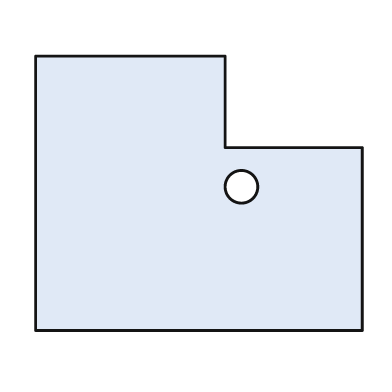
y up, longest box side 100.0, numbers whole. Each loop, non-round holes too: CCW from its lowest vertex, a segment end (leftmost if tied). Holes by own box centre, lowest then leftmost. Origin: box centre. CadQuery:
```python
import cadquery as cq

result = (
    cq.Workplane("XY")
    .moveTo(-50.0, -42.0)
    .lineTo(50.0, -42.0)
    .lineTo(50.0, 14.0)
    .lineTo(8.0, 14.0)
    .lineTo(8.0, 42.0)
    .lineTo(-50.0, 42.0)
    .close()
    .moveTo(13.0, 2.0)
    .circle(5.0)
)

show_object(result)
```